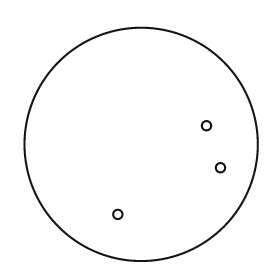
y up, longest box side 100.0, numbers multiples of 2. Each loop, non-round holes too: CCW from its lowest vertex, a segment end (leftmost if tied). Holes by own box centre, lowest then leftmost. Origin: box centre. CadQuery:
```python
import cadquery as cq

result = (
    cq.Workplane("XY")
    .moveTo(0.0, 0.0)
    .circle(50.0)
    .moveTo(-10.0, -30.0)
    .circle(2.0)
    .moveTo(34.0, -10.0)
    .circle(2.0)
    .moveTo(28.0, 8.0)
    .circle(2.0)
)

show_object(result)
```